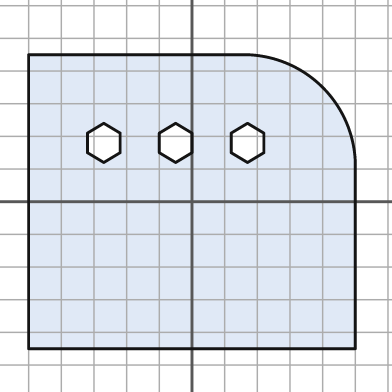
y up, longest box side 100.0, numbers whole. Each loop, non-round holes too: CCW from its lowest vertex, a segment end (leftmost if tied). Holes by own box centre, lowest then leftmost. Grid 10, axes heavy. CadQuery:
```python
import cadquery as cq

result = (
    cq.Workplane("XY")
    .moveTo(-50.0, -45.0)
    .lineTo(50.0, -45.0)
    .lineTo(50.0, 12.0)
    .threePointArc((40.0, 35.0), (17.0, 45.0))
    .lineTo(-50.0, 45.0)
    .close()
    .moveTo(-27.0, 12.0)
    .lineTo(-22.0, 15.0)
    .lineTo(-22.0, 21.0)
    .lineTo(-27.0, 24.0)
    .lineTo(-32.0, 21.0)
    .lineTo(-32.0, 15.0)
    .close()
    .moveTo(-5.0, 12.0)
    .lineTo(0.0, 15.0)
    .lineTo(0.0, 21.0)
    .lineTo(-5.0, 24.0)
    .lineTo(-10.0, 21.0)
    .lineTo(-10.0, 15.0)
    .close()
    .moveTo(17.0, 12.0)
    .lineTo(22.0, 15.0)
    .lineTo(22.0, 21.0)
    .lineTo(17.0, 24.0)
    .lineTo(12.0, 21.0)
    .lineTo(12.0, 15.0)
    .close()
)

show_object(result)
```